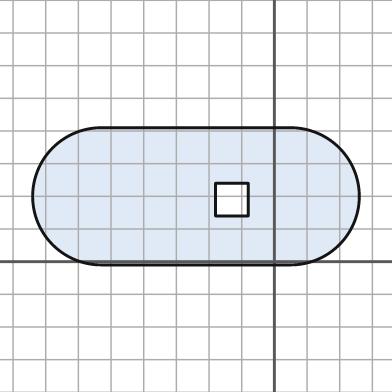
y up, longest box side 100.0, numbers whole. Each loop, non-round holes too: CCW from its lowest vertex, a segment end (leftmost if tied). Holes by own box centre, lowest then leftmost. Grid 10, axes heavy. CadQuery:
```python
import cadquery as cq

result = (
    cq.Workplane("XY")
    .moveTo(-53.0, -1.0)
    .lineTo(5.0, -1.0)
    .threePointArc((26.0, 20.0), (5.0, 41.0))
    .lineTo(-53.0, 41.0)
    .threePointArc((-74.0, 20.0), (-53.0, -1.0))
    .close()
    .moveTo(-18.0, 14.0)
    .lineTo(-8.0, 14.0)
    .lineTo(-8.0, 24.0)
    .lineTo(-18.0, 24.0)
    .close()
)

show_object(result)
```